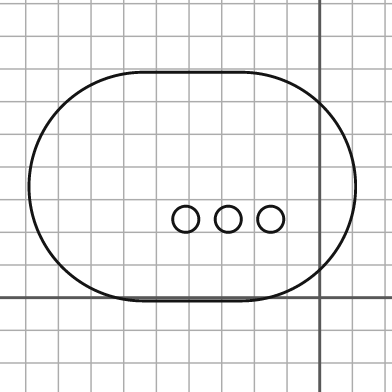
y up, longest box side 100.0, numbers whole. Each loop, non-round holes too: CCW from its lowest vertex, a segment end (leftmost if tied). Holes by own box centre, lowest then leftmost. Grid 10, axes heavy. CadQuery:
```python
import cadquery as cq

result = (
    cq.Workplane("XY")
    .moveTo(-54.0, -1.0)
    .lineTo(-24.0, -1.0)
    .threePointArc((11.0, 34.0), (-24.0, 69.0))
    .lineTo(-54.0, 69.0)
    .threePointArc((-89.0, 34.0), (-54.0, -1.0))
    .close()
    .moveTo(-41.0, 24.0)
    .circle(4.0)
    .moveTo(-28.0, 24.0)
    .circle(4.0)
    .moveTo(-15.0, 24.0)
    .circle(4.0)
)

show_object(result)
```